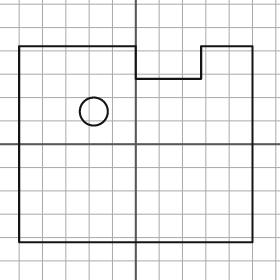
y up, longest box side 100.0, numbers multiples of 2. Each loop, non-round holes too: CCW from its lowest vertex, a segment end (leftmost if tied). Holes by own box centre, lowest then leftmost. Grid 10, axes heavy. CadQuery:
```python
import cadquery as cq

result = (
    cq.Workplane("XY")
    .moveTo(-50.0, -42.0)
    .lineTo(50.0, -42.0)
    .lineTo(50.0, 42.0)
    .lineTo(28.0, 42.0)
    .lineTo(28.0, 28.0)
    .lineTo(0.0, 28.0)
    .lineTo(0.0, 42.0)
    .lineTo(-50.0, 42.0)
    .close()
    .moveTo(-18.0, 14.0)
    .circle(6.0)
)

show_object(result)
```